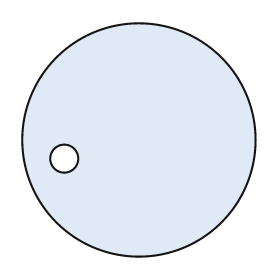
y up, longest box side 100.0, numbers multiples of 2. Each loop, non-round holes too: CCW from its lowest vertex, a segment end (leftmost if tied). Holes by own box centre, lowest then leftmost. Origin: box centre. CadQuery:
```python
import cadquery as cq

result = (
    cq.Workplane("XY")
    .moveTo(0.0, 0.0)
    .circle(50.0)
    .moveTo(-32.0, -8.0)
    .circle(6.0)
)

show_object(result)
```